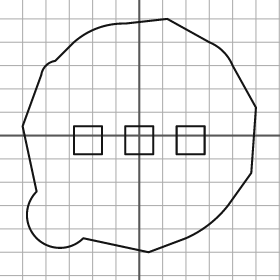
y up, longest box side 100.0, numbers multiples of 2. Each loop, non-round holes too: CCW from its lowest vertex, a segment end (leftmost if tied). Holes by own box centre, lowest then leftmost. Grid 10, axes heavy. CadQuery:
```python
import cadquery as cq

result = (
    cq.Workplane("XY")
    .moveTo(4.0, -50.0)
    .lineTo(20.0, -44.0)
    .threePointArc((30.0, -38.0), (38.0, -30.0))
    .lineTo(48.0, -16.0)
    .lineTo(50.0, 12.0)
    .lineTo(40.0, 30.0)
    .threePointArc((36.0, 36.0), (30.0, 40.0))
    .lineTo(12.0, 50.0)
    .lineTo(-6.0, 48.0)
    .threePointArc((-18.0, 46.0), (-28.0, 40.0))
    .lineTo(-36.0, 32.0)
    .threePointArc((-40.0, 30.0), (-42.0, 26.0))
    .lineTo(-50.0, 4.0)
    .lineTo(-44.0, -24.0)
    .threePointArc((-44.0, -44.0), (-24.0, -44.0))
    .close()
    .moveTo(-28.0, -8.0)
    .lineTo(-16.0, -8.0)
    .lineTo(-16.0, 4.0)
    .lineTo(-28.0, 4.0)
    .close()
    .moveTo(-6.0, -8.0)
    .lineTo(6.0, -8.0)
    .lineTo(6.0, 4.0)
    .lineTo(-6.0, 4.0)
    .close()
    .moveTo(16.0, -8.0)
    .lineTo(28.0, -8.0)
    .lineTo(28.0, 4.0)
    .lineTo(16.0, 4.0)
    .close()
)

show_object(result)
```